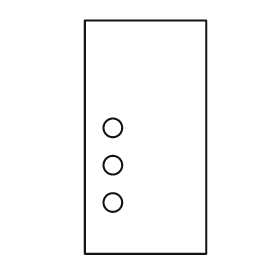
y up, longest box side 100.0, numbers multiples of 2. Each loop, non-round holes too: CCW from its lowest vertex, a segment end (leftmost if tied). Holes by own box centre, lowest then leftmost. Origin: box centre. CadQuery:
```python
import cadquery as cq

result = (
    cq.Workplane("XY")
    .moveTo(-26.0, -50.0)
    .lineTo(26.0, -50.0)
    .lineTo(26.0, 50.0)
    .lineTo(-26.0, 50.0)
    .close()
    .moveTo(-14.0, -28.0)
    .circle(4.0)
    .moveTo(-14.0, -12.0)
    .circle(4.0)
    .moveTo(-14.0, 4.0)
    .circle(4.0)
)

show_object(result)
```